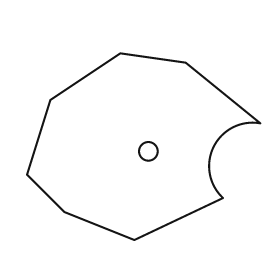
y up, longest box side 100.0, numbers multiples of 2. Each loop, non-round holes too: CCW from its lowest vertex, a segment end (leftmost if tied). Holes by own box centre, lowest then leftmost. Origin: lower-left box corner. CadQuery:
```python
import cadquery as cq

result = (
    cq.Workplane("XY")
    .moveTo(46.0, 0.0)
    .lineTo(84.0, 18.0)
    .threePointArc((80.0, 40.0), (100.0, 50.0))
    .lineTo(68.0, 76.0)
    .lineTo(40.0, 80.0)
    .lineTo(10.0, 60.0)
    .lineTo(0.0, 28.0)
    .lineTo(16.0, 12.0)
    .close()
    .moveTo(52.0, 38.0)
    .circle(4.0)
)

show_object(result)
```